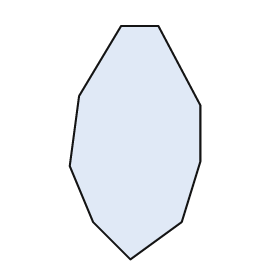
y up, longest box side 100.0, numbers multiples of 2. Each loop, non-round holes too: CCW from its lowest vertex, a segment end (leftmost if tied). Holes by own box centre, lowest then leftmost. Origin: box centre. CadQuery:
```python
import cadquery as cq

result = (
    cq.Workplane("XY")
    .moveTo(-2.0, -50.0)
    .lineTo(20.0, -34.0)
    .lineTo(28.0, -8.0)
    .lineTo(28.0, 16.0)
    .lineTo(10.0, 50.0)
    .lineTo(-6.0, 50.0)
    .lineTo(-24.0, 20.0)
    .lineTo(-28.0, -10.0)
    .lineTo(-18.0, -34.0)
    .close()
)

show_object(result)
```